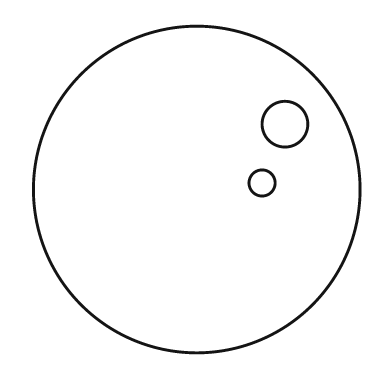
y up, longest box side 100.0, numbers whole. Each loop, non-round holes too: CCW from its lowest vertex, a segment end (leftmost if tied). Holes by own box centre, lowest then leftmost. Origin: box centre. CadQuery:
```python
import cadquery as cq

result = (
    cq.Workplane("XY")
    .moveTo(0.0, 0.0)
    .circle(50.0)
    .moveTo(20.0, 2.0)
    .circle(4.0)
    .moveTo(27.0, 20.0)
    .circle(7.0)
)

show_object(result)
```